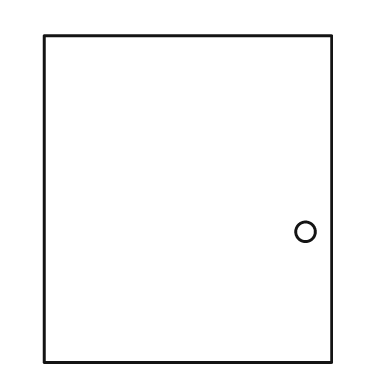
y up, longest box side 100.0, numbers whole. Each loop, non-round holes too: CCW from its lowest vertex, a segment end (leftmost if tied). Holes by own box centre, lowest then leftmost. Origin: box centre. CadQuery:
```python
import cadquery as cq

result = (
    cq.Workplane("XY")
    .moveTo(-44.0, -50.0)
    .lineTo(44.0, -50.0)
    .lineTo(44.0, 50.0)
    .lineTo(-44.0, 50.0)
    .close()
    .moveTo(36.0, -10.0)
    .circle(3.0)
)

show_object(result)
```